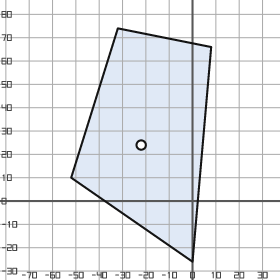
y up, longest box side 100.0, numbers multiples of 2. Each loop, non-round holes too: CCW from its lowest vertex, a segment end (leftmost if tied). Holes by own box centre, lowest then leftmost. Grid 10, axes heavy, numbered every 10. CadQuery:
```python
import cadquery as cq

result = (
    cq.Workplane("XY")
    .moveTo(0.0, -26.0)
    .lineTo(8.0, 66.0)
    .lineTo(-32.0, 74.0)
    .lineTo(-52.0, 10.0)
    .close()
    .moveTo(-22.0, 24.0)
    .circle(2.0)
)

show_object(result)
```